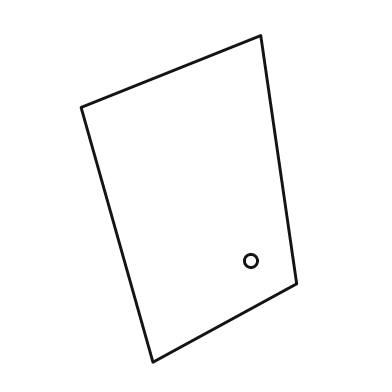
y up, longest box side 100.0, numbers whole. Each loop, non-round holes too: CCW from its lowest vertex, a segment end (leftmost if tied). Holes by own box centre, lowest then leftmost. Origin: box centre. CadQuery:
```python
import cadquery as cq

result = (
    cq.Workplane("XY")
    .moveTo(-11.0, -50.0)
    .lineTo(33.0, -26.0)
    .lineTo(22.0, 50.0)
    .lineTo(-33.0, 28.0)
    .close()
    .moveTo(19.0, -19.0)
    .circle(2.0)
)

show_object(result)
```